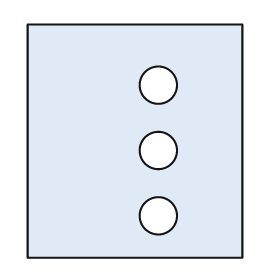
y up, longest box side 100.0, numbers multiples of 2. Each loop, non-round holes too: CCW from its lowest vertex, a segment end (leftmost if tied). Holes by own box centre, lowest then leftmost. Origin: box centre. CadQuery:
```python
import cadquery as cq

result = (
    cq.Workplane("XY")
    .moveTo(-46.0, -50.0)
    .lineTo(46.0, -50.0)
    .lineTo(46.0, 50.0)
    .lineTo(-46.0, 50.0)
    .close()
    .moveTo(10.0, -32.0)
    .circle(8.0)
    .moveTo(10.0, -4.0)
    .circle(8.0)
    .moveTo(10.0, 24.0)
    .circle(8.0)
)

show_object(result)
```